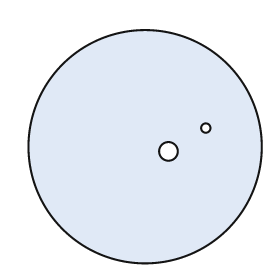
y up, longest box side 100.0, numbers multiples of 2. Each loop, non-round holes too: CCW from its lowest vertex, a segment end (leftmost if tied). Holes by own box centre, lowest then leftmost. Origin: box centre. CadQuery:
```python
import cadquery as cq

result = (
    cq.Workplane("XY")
    .moveTo(0.0, 0.0)
    .circle(50.0)
    .moveTo(10.0, -2.0)
    .circle(4.0)
    .moveTo(26.0, 8.0)
    .circle(2.0)
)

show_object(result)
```